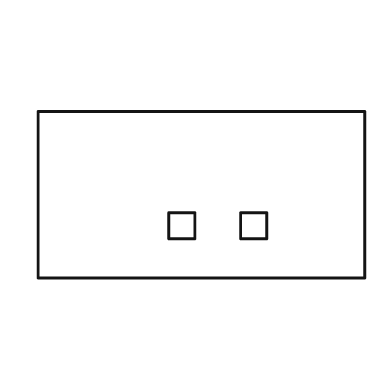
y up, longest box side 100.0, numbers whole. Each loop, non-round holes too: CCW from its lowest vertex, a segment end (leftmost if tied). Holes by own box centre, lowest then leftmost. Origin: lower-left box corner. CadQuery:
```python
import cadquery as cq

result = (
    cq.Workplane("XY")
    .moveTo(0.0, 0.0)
    .lineTo(100.0, 0.0)
    .lineTo(100.0, 51.0)
    .lineTo(0.0, 51.0)
    .close()
    .moveTo(40.0, 12.0)
    .lineTo(48.0, 12.0)
    .lineTo(48.0, 20.0)
    .lineTo(40.0, 20.0)
    .close()
    .moveTo(62.0, 12.0)
    .lineTo(70.0, 12.0)
    .lineTo(70.0, 20.0)
    .lineTo(62.0, 20.0)
    .close()
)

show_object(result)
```